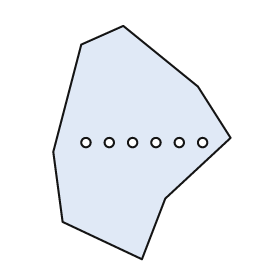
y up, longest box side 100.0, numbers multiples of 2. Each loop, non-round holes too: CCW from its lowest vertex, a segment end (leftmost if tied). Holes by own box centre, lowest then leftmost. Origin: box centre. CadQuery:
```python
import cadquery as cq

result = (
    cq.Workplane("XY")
    .moveTo(0.0, -50.0)
    .lineTo(10.0, -24.0)
    .lineTo(38.0, 2.0)
    .lineTo(24.0, 24.0)
    .lineTo(-8.0, 50.0)
    .lineTo(-26.0, 42.0)
    .lineTo(-38.0, -4.0)
    .lineTo(-34.0, -34.0)
    .close()
    .moveTo(-24.0, 0.0)
    .circle(2.0)
    .moveTo(-14.0, 0.0)
    .circle(2.0)
    .moveTo(-4.0, 0.0)
    .circle(2.0)
    .moveTo(6.0, 0.0)
    .circle(2.0)
    .moveTo(16.0, 0.0)
    .circle(2.0)
    .moveTo(26.0, 0.0)
    .circle(2.0)
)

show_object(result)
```